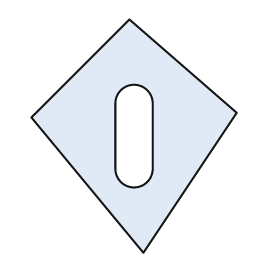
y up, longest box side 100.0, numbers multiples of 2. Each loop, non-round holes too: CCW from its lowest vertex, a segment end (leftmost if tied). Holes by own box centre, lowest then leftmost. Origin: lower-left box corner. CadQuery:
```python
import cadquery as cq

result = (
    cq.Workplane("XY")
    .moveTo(48.0, 0.0)
    .lineTo(88.0, 60.0)
    .lineTo(42.0, 100.0)
    .lineTo(0.0, 58.0)
    .close()
    .moveTo(36.0, 36.0)
    .threePointArc((44.0, 28.0), (52.0, 36.0))
    .lineTo(52.0, 64.0)
    .threePointArc((44.0, 72.0), (36.0, 64.0))
    .close()
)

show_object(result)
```